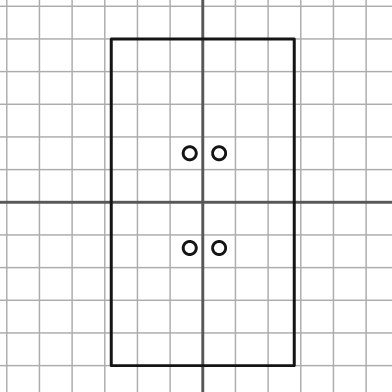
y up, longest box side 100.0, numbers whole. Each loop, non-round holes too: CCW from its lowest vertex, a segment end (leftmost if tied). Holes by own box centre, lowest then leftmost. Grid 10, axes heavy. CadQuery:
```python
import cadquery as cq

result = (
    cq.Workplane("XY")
    .moveTo(-28.0, -50.0)
    .lineTo(28.0, -50.0)
    .lineTo(28.0, 50.0)
    .lineTo(-28.0, 50.0)
    .close()
    .moveTo(-4.0, -14.0)
    .circle(2.0)
    .moveTo(5.0, -14.0)
    .circle(2.0)
    .moveTo(-4.0, 15.0)
    .circle(2.0)
    .moveTo(5.0, 15.0)
    .circle(2.0)
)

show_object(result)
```